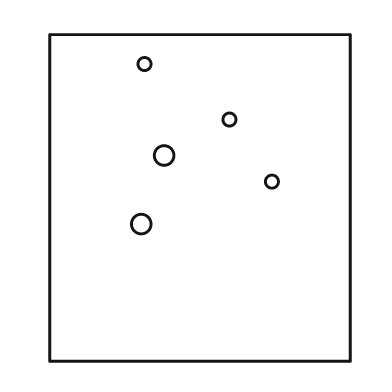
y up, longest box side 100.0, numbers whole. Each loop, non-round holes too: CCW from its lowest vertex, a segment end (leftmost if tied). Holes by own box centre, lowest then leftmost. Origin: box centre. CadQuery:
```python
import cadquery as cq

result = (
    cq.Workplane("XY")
    .moveTo(-46.0, -50.0)
    .lineTo(46.0, -50.0)
    .lineTo(46.0, 50.0)
    .lineTo(-46.0, 50.0)
    .close()
    .moveTo(-18.0, -8.0)
    .circle(3.0)
    .moveTo(22.0, 5.0)
    .circle(2.0)
    .moveTo(-11.0, 13.0)
    .circle(3.0)
    .moveTo(9.0, 24.0)
    .circle(2.0)
    .moveTo(-17.0, 41.0)
    .circle(2.0)
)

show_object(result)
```